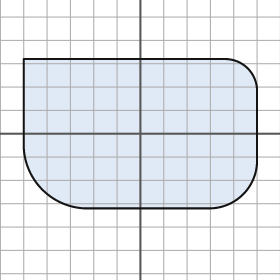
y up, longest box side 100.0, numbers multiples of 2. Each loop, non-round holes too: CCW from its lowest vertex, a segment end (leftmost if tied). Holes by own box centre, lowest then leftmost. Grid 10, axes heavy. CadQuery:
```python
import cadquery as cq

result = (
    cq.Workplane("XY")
    .moveTo(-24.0, -32.0)
    .lineTo(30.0, -32.0)
    .threePointArc((44.0, -26.0), (50.0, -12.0))
    .lineTo(50.0, 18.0)
    .threePointArc((46.0, 28.0), (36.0, 32.0))
    .lineTo(-50.0, 32.0)
    .lineTo(-50.0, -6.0)
    .threePointArc((-42.0, -24.0), (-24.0, -32.0))
    .close()
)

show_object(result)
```